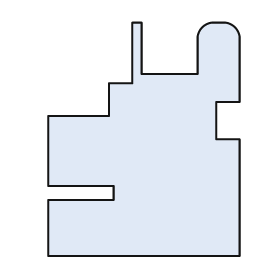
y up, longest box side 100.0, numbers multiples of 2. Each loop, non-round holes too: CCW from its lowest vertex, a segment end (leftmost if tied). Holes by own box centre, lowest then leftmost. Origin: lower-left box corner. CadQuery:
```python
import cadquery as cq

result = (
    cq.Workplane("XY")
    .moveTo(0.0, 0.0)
    .lineTo(82.0, 0.0)
    .lineTo(82.0, 50.0)
    .lineTo(72.0, 50.0)
    .lineTo(72.0, 66.0)
    .lineTo(82.0, 66.0)
    .lineTo(82.0, 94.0)
    .threePointArc((80.0, 98.0), (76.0, 100.0))
    .lineTo(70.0, 100.0)
    .threePointArc((66.0, 98.0), (64.0, 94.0))
    .lineTo(64.0, 78.0)
    .lineTo(40.0, 78.0)
    .lineTo(40.0, 100.0)
    .lineTo(36.0, 100.0)
    .lineTo(36.0, 74.0)
    .lineTo(26.0, 74.0)
    .lineTo(26.0, 60.0)
    .lineTo(0.0, 60.0)
    .lineTo(0.0, 30.0)
    .lineTo(28.0, 30.0)
    .lineTo(28.0, 24.0)
    .lineTo(0.0, 24.0)
    .close()
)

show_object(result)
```